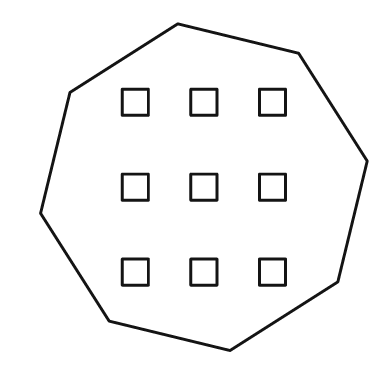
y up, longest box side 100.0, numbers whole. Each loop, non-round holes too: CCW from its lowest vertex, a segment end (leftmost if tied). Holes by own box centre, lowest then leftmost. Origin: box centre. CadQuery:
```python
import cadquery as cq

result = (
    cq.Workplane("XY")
    .moveTo(8.0, -50.0)
    .lineTo(41.0, -29.0)
    .lineTo(50.0, 8.0)
    .lineTo(29.0, 41.0)
    .lineTo(-8.0, 50.0)
    .lineTo(-41.0, 29.0)
    .lineTo(-50.0, -8.0)
    .lineTo(-29.0, -41.0)
    .close()
    .moveTo(-25.0, -30.0)
    .lineTo(-17.0, -30.0)
    .lineTo(-17.0, -22.0)
    .lineTo(-25.0, -22.0)
    .close()
    .moveTo(-4.0, -30.0)
    .lineTo(4.0, -30.0)
    .lineTo(4.0, -22.0)
    .lineTo(-4.0, -22.0)
    .close()
    .moveTo(17.0, -30.0)
    .lineTo(25.0, -30.0)
    .lineTo(25.0, -22.0)
    .lineTo(17.0, -22.0)
    .close()
    .moveTo(-25.0, -4.0)
    .lineTo(-17.0, -4.0)
    .lineTo(-17.0, 4.0)
    .lineTo(-25.0, 4.0)
    .close()
    .moveTo(-4.0, -4.0)
    .lineTo(4.0, -4.0)
    .lineTo(4.0, 4.0)
    .lineTo(-4.0, 4.0)
    .close()
    .moveTo(17.0, -4.0)
    .lineTo(25.0, -4.0)
    .lineTo(25.0, 4.0)
    .lineTo(17.0, 4.0)
    .close()
    .moveTo(-25.0, 22.0)
    .lineTo(-17.0, 22.0)
    .lineTo(-17.0, 30.0)
    .lineTo(-25.0, 30.0)
    .close()
    .moveTo(-4.0, 22.0)
    .lineTo(4.0, 22.0)
    .lineTo(4.0, 30.0)
    .lineTo(-4.0, 30.0)
    .close()
    .moveTo(17.0, 22.0)
    .lineTo(25.0, 22.0)
    .lineTo(25.0, 30.0)
    .lineTo(17.0, 30.0)
    .close()
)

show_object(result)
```